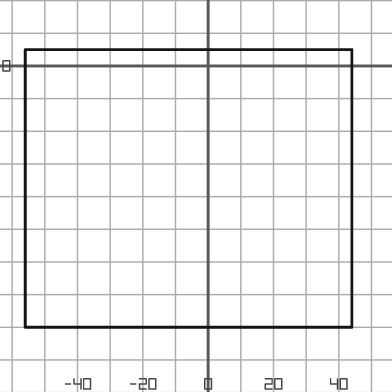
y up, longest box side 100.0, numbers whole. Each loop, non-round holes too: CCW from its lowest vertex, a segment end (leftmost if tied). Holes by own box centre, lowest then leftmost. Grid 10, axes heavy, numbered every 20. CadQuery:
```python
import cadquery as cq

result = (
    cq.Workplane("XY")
    .moveTo(-56.0, -80.0)
    .lineTo(44.0, -80.0)
    .lineTo(44.0, 5.0)
    .lineTo(-56.0, 5.0)
    .close()
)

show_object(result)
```